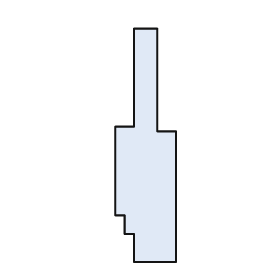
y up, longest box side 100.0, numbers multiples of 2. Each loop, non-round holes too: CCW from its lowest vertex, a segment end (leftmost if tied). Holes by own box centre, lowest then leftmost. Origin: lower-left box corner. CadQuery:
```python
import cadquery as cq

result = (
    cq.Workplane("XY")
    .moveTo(8.0, 0.0)
    .lineTo(26.0, 0.0)
    .lineTo(26.0, 56.0)
    .lineTo(18.0, 56.0)
    .lineTo(18.0, 100.0)
    .lineTo(8.0, 100.0)
    .lineTo(8.0, 58.0)
    .lineTo(0.0, 58.0)
    .lineTo(0.0, 20.0)
    .lineTo(4.0, 20.0)
    .lineTo(4.0, 12.0)
    .lineTo(8.0, 12.0)
    .close()
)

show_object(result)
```